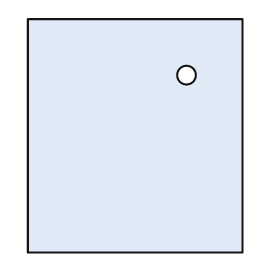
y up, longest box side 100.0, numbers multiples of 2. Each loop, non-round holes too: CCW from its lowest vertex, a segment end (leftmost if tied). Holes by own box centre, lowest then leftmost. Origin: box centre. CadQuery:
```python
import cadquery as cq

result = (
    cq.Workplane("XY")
    .moveTo(-46.0, -50.0)
    .lineTo(46.0, -50.0)
    .lineTo(46.0, 50.0)
    .lineTo(-46.0, 50.0)
    .close()
    .moveTo(22.0, 26.0)
    .circle(4.0)
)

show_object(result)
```